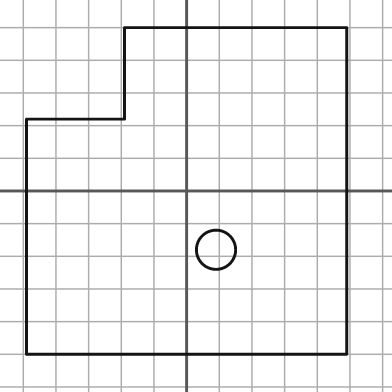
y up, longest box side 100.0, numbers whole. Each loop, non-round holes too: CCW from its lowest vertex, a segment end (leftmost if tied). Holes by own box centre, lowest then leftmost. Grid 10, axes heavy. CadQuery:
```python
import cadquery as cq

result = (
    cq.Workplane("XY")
    .moveTo(-49.0, -50.0)
    .lineTo(49.0, -50.0)
    .lineTo(49.0, 50.0)
    .lineTo(-19.0, 50.0)
    .lineTo(-19.0, 22.0)
    .lineTo(-49.0, 22.0)
    .close()
    .moveTo(9.0, -18.0)
    .circle(6.0)
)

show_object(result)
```